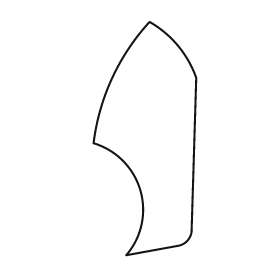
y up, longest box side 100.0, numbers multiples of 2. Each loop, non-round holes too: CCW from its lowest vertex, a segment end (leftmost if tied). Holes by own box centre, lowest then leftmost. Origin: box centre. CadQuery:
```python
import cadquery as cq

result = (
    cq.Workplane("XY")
    .moveTo(-8.0, -50.0)
    .lineTo(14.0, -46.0)
    .threePointArc((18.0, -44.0), (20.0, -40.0))
    .lineTo(22.0, 26.0)
    .threePointArc((14.0, 40.0), (2.0, 50.0))
    .threePointArc((-14.0, 26.0), (-22.0, -2.0))
    .threePointArc((-2.0, -22.0), (-8.0, -50.0))
    .close()
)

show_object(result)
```